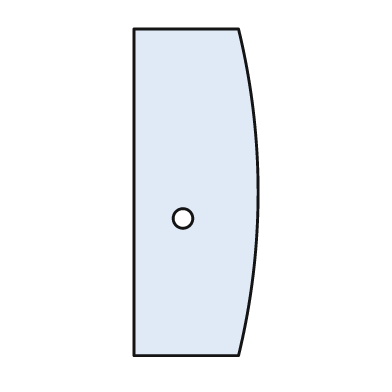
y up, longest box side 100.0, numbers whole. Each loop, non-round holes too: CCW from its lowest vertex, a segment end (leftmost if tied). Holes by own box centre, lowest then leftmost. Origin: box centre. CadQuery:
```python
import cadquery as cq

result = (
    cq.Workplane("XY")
    .moveTo(-19.0, -50.0)
    .lineTo(13.0, -50.0)
    .threePointArc((19.0, 0.0), (13.0, 50.0))
    .lineTo(-19.0, 50.0)
    .close()
    .moveTo(-4.0, -8.0)
    .circle(3.0)
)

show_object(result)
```